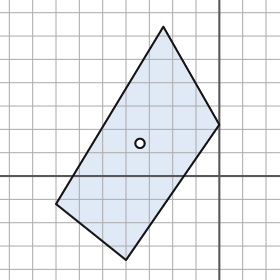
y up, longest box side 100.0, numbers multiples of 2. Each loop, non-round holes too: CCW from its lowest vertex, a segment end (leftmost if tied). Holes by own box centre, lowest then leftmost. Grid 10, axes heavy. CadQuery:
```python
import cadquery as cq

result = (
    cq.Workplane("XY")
    .moveTo(-40.0, -36.0)
    .lineTo(0.0, 22.0)
    .lineTo(-24.0, 64.0)
    .lineTo(-70.0, -12.0)
    .close()
    .moveTo(-34.0, 14.0)
    .circle(2.0)
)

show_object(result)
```